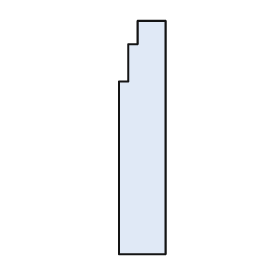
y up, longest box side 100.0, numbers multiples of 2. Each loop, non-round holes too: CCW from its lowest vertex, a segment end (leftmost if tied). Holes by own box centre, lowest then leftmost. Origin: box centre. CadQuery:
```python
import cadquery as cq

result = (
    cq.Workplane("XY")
    .moveTo(-10.0, -50.0)
    .lineTo(10.0, -50.0)
    .lineTo(10.0, 50.0)
    .lineTo(-2.0, 50.0)
    .lineTo(-2.0, 40.0)
    .lineTo(-6.0, 40.0)
    .lineTo(-6.0, 24.0)
    .lineTo(-10.0, 24.0)
    .close()
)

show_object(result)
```